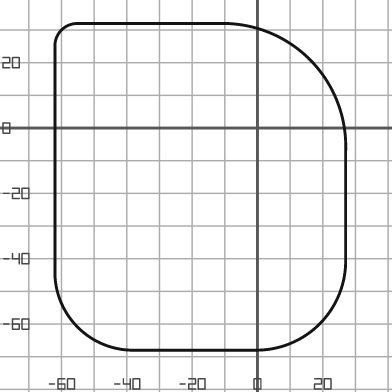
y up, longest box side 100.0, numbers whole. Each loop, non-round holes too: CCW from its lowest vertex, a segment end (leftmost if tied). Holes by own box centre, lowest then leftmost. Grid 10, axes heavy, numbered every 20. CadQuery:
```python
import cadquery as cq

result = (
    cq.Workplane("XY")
    .moveTo(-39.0, -68.0)
    .lineTo(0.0, -68.0)
    .threePointArc((19.0, -60.0), (27.0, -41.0))
    .lineTo(27.0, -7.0)
    .threePointArc((16.0, 21.0), (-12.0, 32.0))
    .lineTo(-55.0, 32.0)
    .threePointArc((-60.0, 30.0), (-62.0, 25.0))
    .lineTo(-62.0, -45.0)
    .threePointArc((-55.0, -61.0), (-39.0, -68.0))
    .close()
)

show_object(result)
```